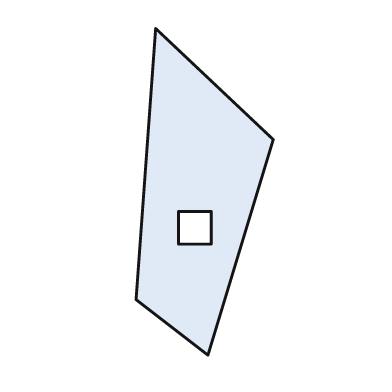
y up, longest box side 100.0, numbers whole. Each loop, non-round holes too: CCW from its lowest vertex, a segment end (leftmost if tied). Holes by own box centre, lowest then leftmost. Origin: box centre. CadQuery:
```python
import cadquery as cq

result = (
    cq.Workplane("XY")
    .moveTo(1.0, -50.0)
    .lineTo(21.0, 16.0)
    .lineTo(-15.0, 50.0)
    .lineTo(-21.0, -33.0)
    .close()
    .moveTo(-8.0, -16.0)
    .lineTo(2.0, -16.0)
    .lineTo(2.0, -6.0)
    .lineTo(-8.0, -6.0)
    .close()
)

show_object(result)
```